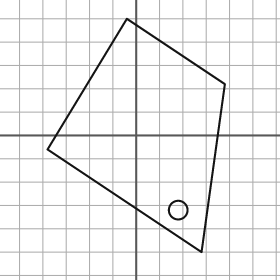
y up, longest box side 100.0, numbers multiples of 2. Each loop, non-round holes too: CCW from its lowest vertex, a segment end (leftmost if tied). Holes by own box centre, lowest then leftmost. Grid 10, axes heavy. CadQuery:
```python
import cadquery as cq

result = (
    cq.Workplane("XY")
    .moveTo(28.0, -50.0)
    .lineTo(38.0, 22.0)
    .lineTo(-4.0, 50.0)
    .lineTo(-38.0, -6.0)
    .close()
    .moveTo(18.0, -32.0)
    .circle(4.0)
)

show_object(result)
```